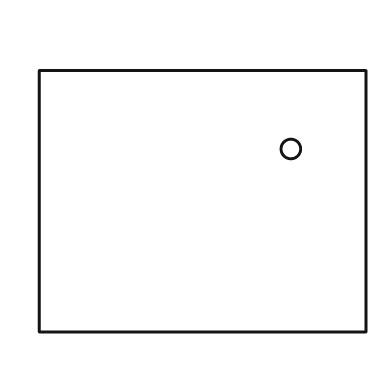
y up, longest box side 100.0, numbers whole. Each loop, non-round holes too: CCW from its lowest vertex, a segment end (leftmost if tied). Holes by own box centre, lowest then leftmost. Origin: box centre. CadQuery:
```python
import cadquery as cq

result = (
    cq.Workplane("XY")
    .moveTo(-50.0, -40.0)
    .lineTo(50.0, -40.0)
    .lineTo(50.0, 40.0)
    .lineTo(-50.0, 40.0)
    .close()
    .moveTo(27.0, 16.0)
    .circle(3.0)
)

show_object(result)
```